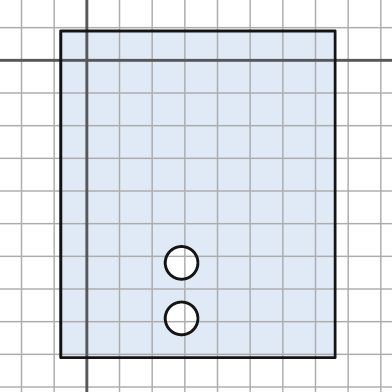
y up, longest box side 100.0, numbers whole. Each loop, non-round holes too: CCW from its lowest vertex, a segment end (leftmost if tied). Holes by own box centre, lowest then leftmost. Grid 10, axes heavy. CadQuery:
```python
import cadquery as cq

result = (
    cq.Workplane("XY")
    .moveTo(-8.0, -91.0)
    .lineTo(76.0, -91.0)
    .lineTo(76.0, 9.0)
    .lineTo(-8.0, 9.0)
    .close()
    .moveTo(29.0, -79.0)
    .circle(5.0)
    .moveTo(29.0, -62.0)
    .circle(5.0)
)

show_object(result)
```